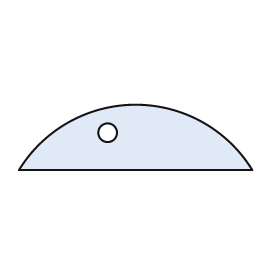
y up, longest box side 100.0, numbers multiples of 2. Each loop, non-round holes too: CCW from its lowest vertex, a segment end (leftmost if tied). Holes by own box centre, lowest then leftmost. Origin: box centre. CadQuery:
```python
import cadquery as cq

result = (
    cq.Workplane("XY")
    .moveTo(-50.0, -14.0)
    .lineTo(50.0, -14.0)
    .threePointArc((0.0, 14.0), (-50.0, -14.0))
    .close()
    .moveTo(-12.0, 2.0)
    .circle(4.0)
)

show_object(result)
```